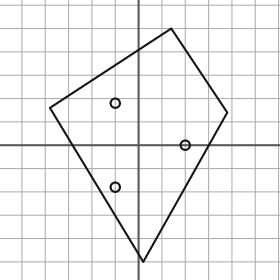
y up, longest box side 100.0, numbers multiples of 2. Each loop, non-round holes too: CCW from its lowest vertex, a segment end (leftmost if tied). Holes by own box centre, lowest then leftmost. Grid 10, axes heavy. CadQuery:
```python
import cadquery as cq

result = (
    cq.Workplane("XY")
    .moveTo(2.0, -50.0)
    .lineTo(38.0, 14.0)
    .lineTo(14.0, 50.0)
    .lineTo(-38.0, 16.0)
    .close()
    .moveTo(-10.0, -18.0)
    .circle(2.0)
    .moveTo(20.0, 0.0)
    .circle(2.0)
    .moveTo(-10.0, 18.0)
    .circle(2.0)
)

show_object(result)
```